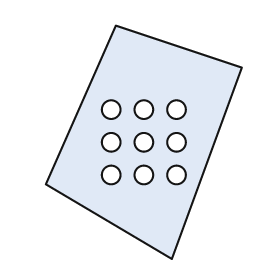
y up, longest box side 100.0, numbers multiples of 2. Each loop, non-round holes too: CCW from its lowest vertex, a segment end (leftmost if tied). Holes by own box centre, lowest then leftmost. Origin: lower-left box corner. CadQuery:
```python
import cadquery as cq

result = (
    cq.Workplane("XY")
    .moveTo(54.0, 0.0)
    .lineTo(84.0, 82.0)
    .lineTo(30.0, 100.0)
    .lineTo(0.0, 32.0)
    .close()
    .moveTo(28.0, 36.0)
    .circle(4.0)
    .moveTo(42.0, 36.0)
    .circle(4.0)
    .moveTo(56.0, 36.0)
    .circle(4.0)
    .moveTo(28.0, 50.0)
    .circle(4.0)
    .moveTo(42.0, 50.0)
    .circle(4.0)
    .moveTo(56.0, 50.0)
    .circle(4.0)
    .moveTo(28.0, 64.0)
    .circle(4.0)
    .moveTo(42.0, 64.0)
    .circle(4.0)
    .moveTo(56.0, 64.0)
    .circle(4.0)
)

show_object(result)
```